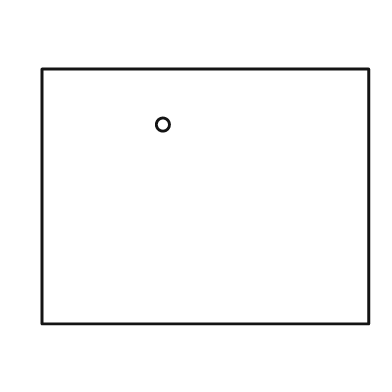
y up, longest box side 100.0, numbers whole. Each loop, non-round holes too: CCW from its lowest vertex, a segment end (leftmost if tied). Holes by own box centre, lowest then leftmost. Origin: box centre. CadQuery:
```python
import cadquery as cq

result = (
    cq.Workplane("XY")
    .moveTo(-50.0, -39.0)
    .lineTo(50.0, -39.0)
    .lineTo(50.0, 39.0)
    .lineTo(-50.0, 39.0)
    .close()
    .moveTo(-13.0, 22.0)
    .circle(2.0)
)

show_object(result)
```